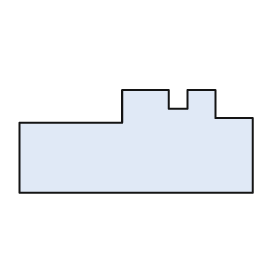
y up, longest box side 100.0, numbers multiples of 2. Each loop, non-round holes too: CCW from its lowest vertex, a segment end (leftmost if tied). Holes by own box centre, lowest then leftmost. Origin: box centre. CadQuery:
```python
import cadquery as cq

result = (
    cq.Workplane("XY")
    .moveTo(-50.0, -22.0)
    .lineTo(50.0, -22.0)
    .lineTo(50.0, 10.0)
    .lineTo(34.0, 10.0)
    .lineTo(34.0, 22.0)
    .lineTo(22.0, 22.0)
    .lineTo(22.0, 14.0)
    .lineTo(14.0, 14.0)
    .lineTo(14.0, 22.0)
    .lineTo(-6.0, 22.0)
    .lineTo(-6.0, 8.0)
    .lineTo(-50.0, 8.0)
    .close()
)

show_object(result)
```